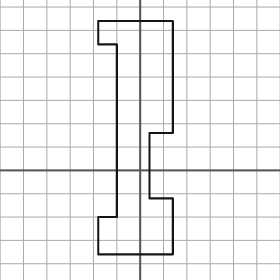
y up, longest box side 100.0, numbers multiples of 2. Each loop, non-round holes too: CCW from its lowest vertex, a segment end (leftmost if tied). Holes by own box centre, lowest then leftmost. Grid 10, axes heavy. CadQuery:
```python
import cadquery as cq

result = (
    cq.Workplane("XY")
    .moveTo(-18.0, -36.0)
    .lineTo(14.0, -36.0)
    .lineTo(14.0, -12.0)
    .lineTo(4.0, -12.0)
    .lineTo(4.0, 16.0)
    .lineTo(14.0, 16.0)
    .lineTo(14.0, 64.0)
    .lineTo(-18.0, 64.0)
    .lineTo(-18.0, 54.0)
    .lineTo(-10.0, 54.0)
    .lineTo(-10.0, -20.0)
    .lineTo(-18.0, -20.0)
    .close()
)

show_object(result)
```